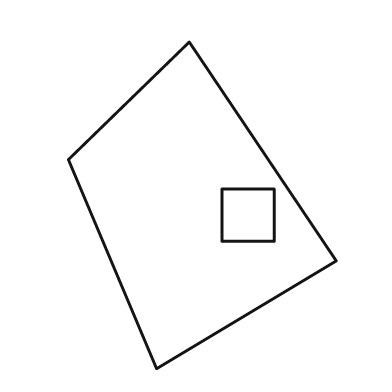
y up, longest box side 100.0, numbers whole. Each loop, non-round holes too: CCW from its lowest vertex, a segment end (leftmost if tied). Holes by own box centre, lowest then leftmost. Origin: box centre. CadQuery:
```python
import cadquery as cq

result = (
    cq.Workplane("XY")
    .moveTo(-14.0, -50.0)
    .lineTo(41.0, -17.0)
    .lineTo(-4.0, 50.0)
    .lineTo(-41.0, 14.0)
    .close()
    .moveTo(6.0, -11.0)
    .lineTo(22.0, -11.0)
    .lineTo(22.0, 5.0)
    .lineTo(6.0, 5.0)
    .close()
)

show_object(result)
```